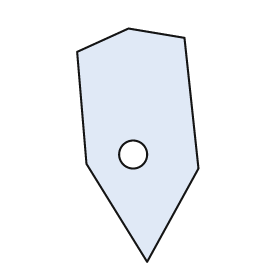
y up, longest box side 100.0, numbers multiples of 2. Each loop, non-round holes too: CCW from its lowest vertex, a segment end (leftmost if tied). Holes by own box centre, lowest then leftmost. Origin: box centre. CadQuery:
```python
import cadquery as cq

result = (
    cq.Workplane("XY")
    .moveTo(4.0, -50.0)
    .lineTo(26.0, -10.0)
    .lineTo(20.0, 46.0)
    .lineTo(-4.0, 50.0)
    .lineTo(-26.0, 40.0)
    .lineTo(-22.0, -8.0)
    .close()
    .moveTo(-2.0, -4.0)
    .circle(6.0)
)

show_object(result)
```